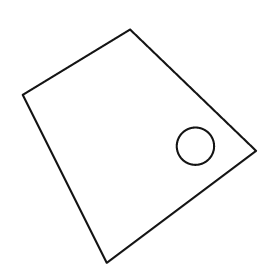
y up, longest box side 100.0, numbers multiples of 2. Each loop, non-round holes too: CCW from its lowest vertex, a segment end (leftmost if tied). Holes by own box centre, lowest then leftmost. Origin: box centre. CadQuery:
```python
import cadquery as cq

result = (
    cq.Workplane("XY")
    .moveTo(-14.0, -50.0)
    .lineTo(50.0, -2.0)
    .lineTo(-4.0, 50.0)
    .lineTo(-50.0, 22.0)
    .close()
    .moveTo(24.0, 0.0)
    .circle(8.0)
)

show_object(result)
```